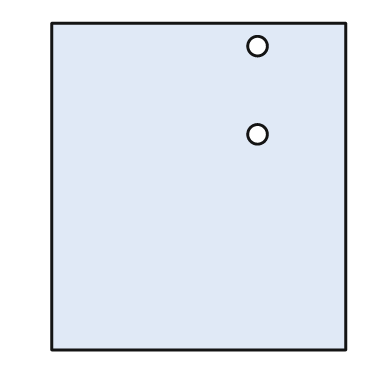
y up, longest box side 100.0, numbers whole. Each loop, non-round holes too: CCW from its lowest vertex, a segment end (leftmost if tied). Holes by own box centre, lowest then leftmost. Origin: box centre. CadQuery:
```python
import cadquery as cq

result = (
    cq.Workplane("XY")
    .moveTo(-45.0, -50.0)
    .lineTo(45.0, -50.0)
    .lineTo(45.0, 50.0)
    .lineTo(-45.0, 50.0)
    .close()
    .moveTo(18.0, 16.0)
    .circle(3.0)
    .moveTo(18.0, 43.0)
    .circle(3.0)
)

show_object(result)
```